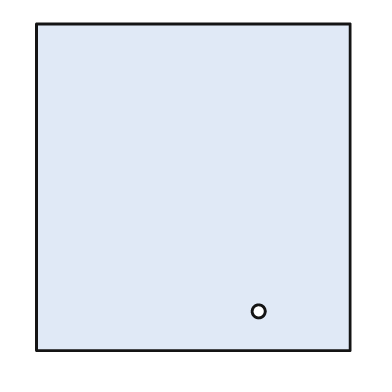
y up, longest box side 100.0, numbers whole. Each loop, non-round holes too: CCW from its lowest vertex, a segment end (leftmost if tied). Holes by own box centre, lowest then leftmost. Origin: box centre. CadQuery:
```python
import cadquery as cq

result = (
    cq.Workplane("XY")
    .moveTo(-48.0, -50.0)
    .lineTo(48.0, -50.0)
    .lineTo(48.0, 50.0)
    .lineTo(-48.0, 50.0)
    .close()
    .moveTo(20.0, -38.0)
    .circle(2.0)
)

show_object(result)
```